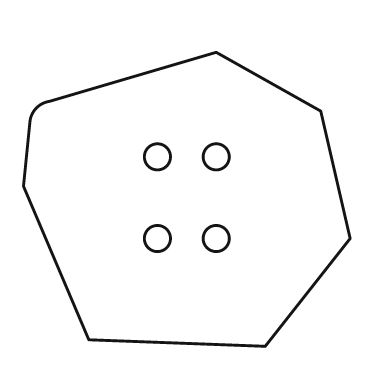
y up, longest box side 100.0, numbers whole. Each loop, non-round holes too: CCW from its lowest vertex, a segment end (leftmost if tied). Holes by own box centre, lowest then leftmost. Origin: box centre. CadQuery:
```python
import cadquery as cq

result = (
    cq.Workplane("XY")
    .moveTo(24.0, -45.0)
    .lineTo(50.0, -12.0)
    .lineTo(41.0, 27.0)
    .lineTo(9.0, 45.0)
    .lineTo(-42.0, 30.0)
    .threePointArc((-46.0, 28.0), (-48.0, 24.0))
    .lineTo(-50.0, 4.0)
    .lineTo(-30.0, -43.0)
    .close()
    .moveTo(-9.0, -12.0)
    .circle(4.0)
    .moveTo(9.0, -12.0)
    .circle(4.0)
    .moveTo(-9.0, 13.0)
    .circle(4.0)
    .moveTo(9.0, 13.0)
    .circle(4.0)
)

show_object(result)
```